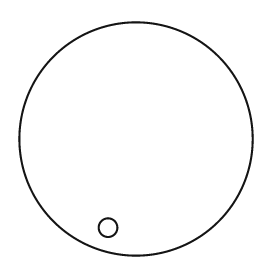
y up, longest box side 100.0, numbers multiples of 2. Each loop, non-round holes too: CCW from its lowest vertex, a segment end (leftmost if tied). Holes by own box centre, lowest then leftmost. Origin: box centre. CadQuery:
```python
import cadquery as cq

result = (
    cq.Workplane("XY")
    .moveTo(0.0, 0.0)
    .circle(50.0)
    .moveTo(-12.0, -38.0)
    .circle(4.0)
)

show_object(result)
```